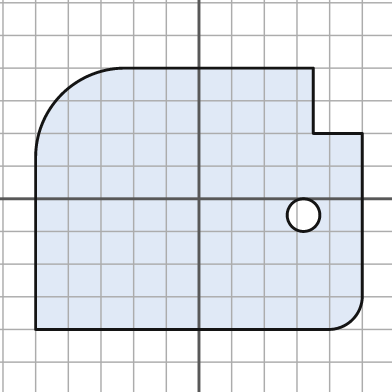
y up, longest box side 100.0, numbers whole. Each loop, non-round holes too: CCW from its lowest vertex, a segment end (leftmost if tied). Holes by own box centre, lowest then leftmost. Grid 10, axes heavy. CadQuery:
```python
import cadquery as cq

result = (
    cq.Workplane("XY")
    .moveTo(-50.0, -40.0)
    .lineTo(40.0, -40.0)
    .threePointArc((47.0, -37.0), (50.0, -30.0))
    .lineTo(50.0, 20.0)
    .lineTo(35.0, 20.0)
    .lineTo(35.0, 40.0)
    .lineTo(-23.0, 40.0)
    .threePointArc((-42.0, 32.0), (-50.0, 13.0))
    .close()
    .moveTo(32.0, -5.0)
    .circle(5.0)
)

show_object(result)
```